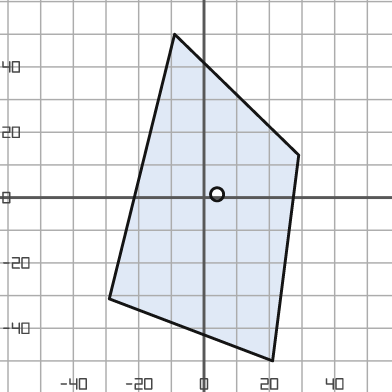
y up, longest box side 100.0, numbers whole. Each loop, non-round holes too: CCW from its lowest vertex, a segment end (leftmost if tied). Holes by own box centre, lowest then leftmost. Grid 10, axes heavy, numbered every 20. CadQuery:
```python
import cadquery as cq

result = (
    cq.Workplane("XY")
    .moveTo(21.0, -50.0)
    .lineTo(29.0, 13.0)
    .lineTo(-9.0, 50.0)
    .lineTo(-29.0, -31.0)
    .close()
    .moveTo(4.0, 1.0)
    .circle(2.0)
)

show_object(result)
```